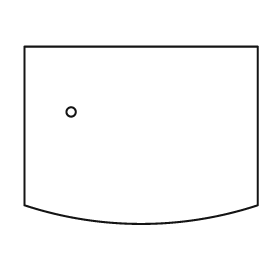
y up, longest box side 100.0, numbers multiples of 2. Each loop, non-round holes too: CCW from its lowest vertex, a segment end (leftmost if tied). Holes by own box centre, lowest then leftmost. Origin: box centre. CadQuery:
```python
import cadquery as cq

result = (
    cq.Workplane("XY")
    .moveTo(-50.0, -30.0)
    .threePointArc((0.0, -38.0), (50.0, -30.0))
    .lineTo(50.0, 38.0)
    .lineTo(-50.0, 38.0)
    .close()
    .moveTo(-30.0, 10.0)
    .circle(2.0)
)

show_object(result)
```